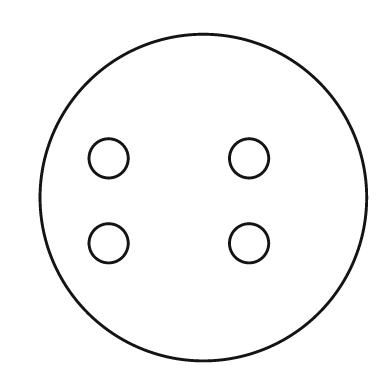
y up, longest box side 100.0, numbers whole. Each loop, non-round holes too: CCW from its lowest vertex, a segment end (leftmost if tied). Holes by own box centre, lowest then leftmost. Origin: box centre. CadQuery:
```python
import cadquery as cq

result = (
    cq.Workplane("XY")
    .moveTo(0.0, 0.0)
    .circle(50.0)
    .moveTo(-29.0, -14.0)
    .circle(6.0)
    .moveTo(14.0, -14.0)
    .circle(6.0)
    .moveTo(-29.0, 12.0)
    .circle(6.0)
    .moveTo(14.0, 12.0)
    .circle(6.0)
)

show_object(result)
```